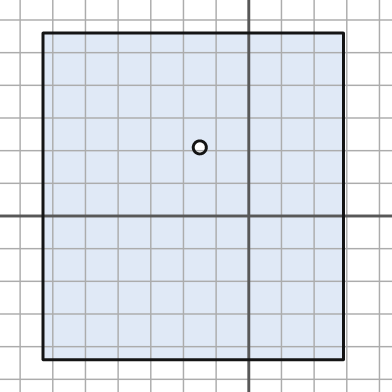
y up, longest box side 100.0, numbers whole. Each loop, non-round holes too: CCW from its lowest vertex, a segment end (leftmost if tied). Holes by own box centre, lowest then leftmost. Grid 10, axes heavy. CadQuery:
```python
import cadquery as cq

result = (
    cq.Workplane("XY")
    .moveTo(-63.0, -44.0)
    .lineTo(29.0, -44.0)
    .lineTo(29.0, 56.0)
    .lineTo(-63.0, 56.0)
    .close()
    .moveTo(-15.0, 21.0)
    .circle(2.0)
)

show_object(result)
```